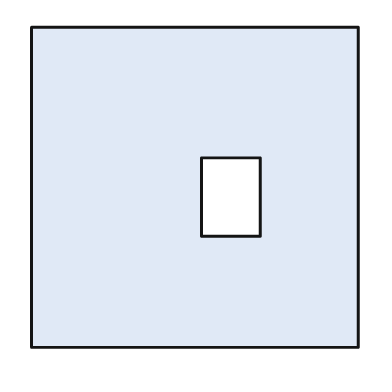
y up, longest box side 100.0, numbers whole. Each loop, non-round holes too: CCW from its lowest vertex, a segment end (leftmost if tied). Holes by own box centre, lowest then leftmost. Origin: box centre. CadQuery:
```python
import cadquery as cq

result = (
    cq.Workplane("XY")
    .moveTo(-50.0, -49.0)
    .lineTo(50.0, -49.0)
    .lineTo(50.0, 49.0)
    .lineTo(-50.0, 49.0)
    .close()
    .moveTo(2.0, -15.0)
    .lineTo(20.0, -15.0)
    .lineTo(20.0, 9.0)
    .lineTo(2.0, 9.0)
    .close()
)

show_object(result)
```